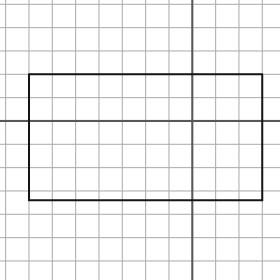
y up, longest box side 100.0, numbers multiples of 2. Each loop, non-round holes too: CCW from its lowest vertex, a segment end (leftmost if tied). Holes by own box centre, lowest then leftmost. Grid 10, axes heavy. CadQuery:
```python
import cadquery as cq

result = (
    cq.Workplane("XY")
    .moveTo(-70.0, -34.0)
    .lineTo(30.0, -34.0)
    .lineTo(30.0, 20.0)
    .lineTo(-70.0, 20.0)
    .close()
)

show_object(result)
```